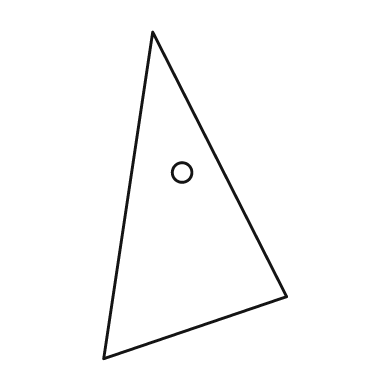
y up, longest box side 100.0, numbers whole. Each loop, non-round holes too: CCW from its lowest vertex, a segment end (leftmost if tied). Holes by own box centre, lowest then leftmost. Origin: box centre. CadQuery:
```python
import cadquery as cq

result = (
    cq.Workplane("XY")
    .moveTo(-28.0, -50.0)
    .lineTo(28.0, -31.0)
    .lineTo(-13.0, 50.0)
    .close()
    .moveTo(-4.0, 7.0)
    .circle(3.0)
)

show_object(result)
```